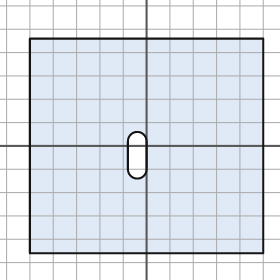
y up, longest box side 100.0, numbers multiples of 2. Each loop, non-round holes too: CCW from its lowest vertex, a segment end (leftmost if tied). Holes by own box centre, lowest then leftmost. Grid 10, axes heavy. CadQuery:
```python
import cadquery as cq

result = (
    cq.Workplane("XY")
    .moveTo(-50.0, -46.0)
    .lineTo(50.0, -46.0)
    .lineTo(50.0, 46.0)
    .lineTo(-50.0, 46.0)
    .close()
    .moveTo(-8.0, -10.0)
    .threePointArc((-4.0, -14.0), (0.0, -10.0))
    .lineTo(0.0, 2.0)
    .threePointArc((-4.0, 6.0), (-8.0, 2.0))
    .close()
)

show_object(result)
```